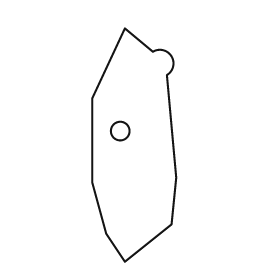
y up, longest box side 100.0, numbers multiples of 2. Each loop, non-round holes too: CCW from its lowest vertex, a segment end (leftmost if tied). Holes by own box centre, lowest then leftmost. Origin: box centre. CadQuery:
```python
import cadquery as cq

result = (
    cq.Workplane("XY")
    .moveTo(-4.0, -50.0)
    .lineTo(16.0, -34.0)
    .lineTo(18.0, -14.0)
    .lineTo(14.0, 30.0)
    .threePointArc((16.0, 38.0), (8.0, 40.0))
    .lineTo(-4.0, 50.0)
    .lineTo(-18.0, 20.0)
    .lineTo(-18.0, -16.0)
    .lineTo(-12.0, -38.0)
    .close()
    .moveTo(-6.0, 6.0)
    .circle(4.0)
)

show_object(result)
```